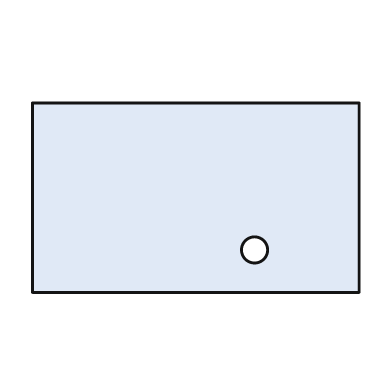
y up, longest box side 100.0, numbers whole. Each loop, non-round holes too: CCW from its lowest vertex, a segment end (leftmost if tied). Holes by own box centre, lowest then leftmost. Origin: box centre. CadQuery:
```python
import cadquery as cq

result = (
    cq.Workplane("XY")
    .moveTo(-50.0, -29.0)
    .lineTo(50.0, -29.0)
    .lineTo(50.0, 29.0)
    .lineTo(-50.0, 29.0)
    .close()
    .moveTo(18.0, -16.0)
    .circle(4.0)
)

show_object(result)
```